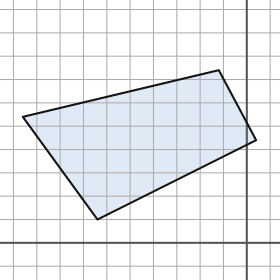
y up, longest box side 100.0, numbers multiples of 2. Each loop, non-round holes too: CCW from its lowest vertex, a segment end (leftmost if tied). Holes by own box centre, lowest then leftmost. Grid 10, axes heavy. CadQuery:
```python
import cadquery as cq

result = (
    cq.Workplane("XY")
    .moveTo(-64.0, 10.0)
    .lineTo(4.0, 44.0)
    .lineTo(-12.0, 74.0)
    .lineTo(-96.0, 54.0)
    .close()
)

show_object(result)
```